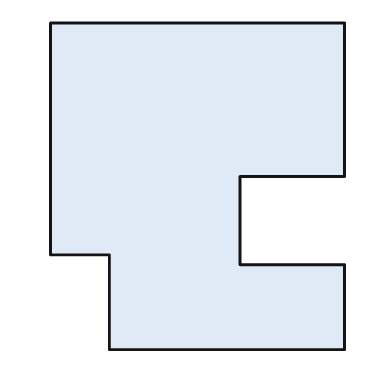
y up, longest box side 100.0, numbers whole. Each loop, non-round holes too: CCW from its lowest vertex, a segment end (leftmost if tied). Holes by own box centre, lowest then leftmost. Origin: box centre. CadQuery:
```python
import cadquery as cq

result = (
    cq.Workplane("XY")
    .moveTo(-27.0, -50.0)
    .lineTo(45.0, -50.0)
    .lineTo(45.0, -24.0)
    .lineTo(13.0, -24.0)
    .lineTo(13.0, 3.0)
    .lineTo(45.0, 3.0)
    .lineTo(45.0, 50.0)
    .lineTo(-45.0, 50.0)
    .lineTo(-45.0, -21.0)
    .lineTo(-27.0, -21.0)
    .close()
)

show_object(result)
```